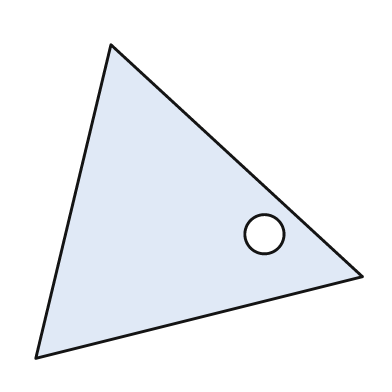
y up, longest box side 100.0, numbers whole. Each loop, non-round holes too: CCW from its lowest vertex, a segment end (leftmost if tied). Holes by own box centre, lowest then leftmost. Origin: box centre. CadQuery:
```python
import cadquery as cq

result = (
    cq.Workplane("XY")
    .moveTo(-50.0, -48.0)
    .lineTo(50.0, -23.0)
    .lineTo(-27.0, 48.0)
    .close()
    .moveTo(20.0, -10.0)
    .circle(6.0)
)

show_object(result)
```